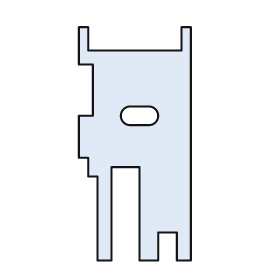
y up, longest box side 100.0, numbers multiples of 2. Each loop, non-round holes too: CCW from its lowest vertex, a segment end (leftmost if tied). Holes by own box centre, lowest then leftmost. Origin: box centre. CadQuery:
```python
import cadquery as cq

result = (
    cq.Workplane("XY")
    .moveTo(-16.0, -50.0)
    .lineTo(-10.0, -50.0)
    .lineTo(-10.0, -10.0)
    .lineTo(2.0, -10.0)
    .lineTo(2.0, -50.0)
    .lineTo(10.0, -50.0)
    .lineTo(10.0, -38.0)
    .lineTo(18.0, -38.0)
    .lineTo(18.0, -50.0)
    .lineTo(24.0, -50.0)
    .lineTo(24.0, 50.0)
    .lineTo(20.0, 50.0)
    .lineTo(20.0, 40.0)
    .lineTo(-20.0, 40.0)
    .lineTo(-20.0, 50.0)
    .lineTo(-24.0, 50.0)
    .lineTo(-24.0, 34.0)
    .lineTo(-18.0, 34.0)
    .lineTo(-18.0, 12.0)
    .lineTo(-24.0, 12.0)
    .lineTo(-24.0, -6.0)
    .lineTo(-20.0, -6.0)
    .lineTo(-20.0, -14.0)
    .lineTo(-16.0, -14.0)
    .close()
    .moveTo(-2.0, 8.0)
    .lineTo(6.0, 8.0)
    .threePointArc((10.0, 12.0), (6.0, 16.0))
    .lineTo(-2.0, 16.0)
    .threePointArc((-6.0, 12.0), (-2.0, 8.0))
    .close()
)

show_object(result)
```